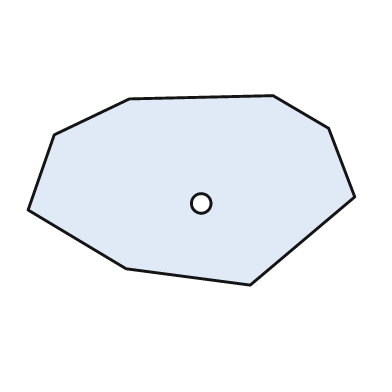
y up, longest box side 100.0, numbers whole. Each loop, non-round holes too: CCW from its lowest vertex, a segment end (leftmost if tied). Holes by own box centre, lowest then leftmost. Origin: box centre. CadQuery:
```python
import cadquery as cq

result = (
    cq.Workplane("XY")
    .moveTo(18.0, -29.0)
    .lineTo(50.0, -2.0)
    .lineTo(42.0, 19.0)
    .lineTo(25.0, 29.0)
    .lineTo(-19.0, 28.0)
    .lineTo(-42.0, 17.0)
    .lineTo(-50.0, -6.0)
    .lineTo(-20.0, -24.0)
    .close()
    .moveTo(3.0, -4.0)
    .circle(3.0)
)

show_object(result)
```